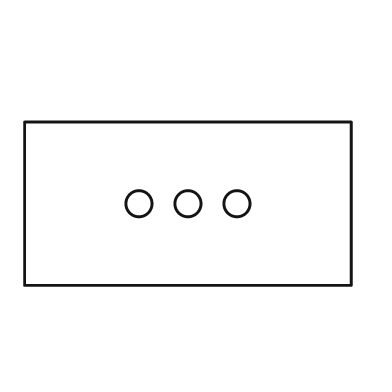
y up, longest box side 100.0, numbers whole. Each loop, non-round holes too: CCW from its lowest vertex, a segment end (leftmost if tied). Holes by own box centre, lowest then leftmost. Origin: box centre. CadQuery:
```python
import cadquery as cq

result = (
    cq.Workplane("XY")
    .moveTo(-50.0, -25.0)
    .lineTo(50.0, -25.0)
    .lineTo(50.0, 25.0)
    .lineTo(-50.0, 25.0)
    .close()
    .moveTo(-15.0, 0.0)
    .circle(4.0)
    .moveTo(0.0, 0.0)
    .circle(4.0)
    .moveTo(15.0, 0.0)
    .circle(4.0)
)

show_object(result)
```